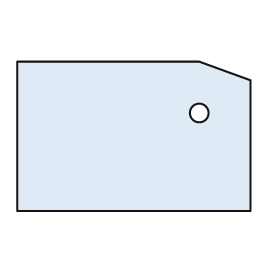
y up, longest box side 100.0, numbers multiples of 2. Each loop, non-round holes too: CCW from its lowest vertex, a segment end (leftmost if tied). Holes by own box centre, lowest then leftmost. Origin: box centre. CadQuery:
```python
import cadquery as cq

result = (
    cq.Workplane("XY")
    .moveTo(-50.0, -32.0)
    .lineTo(50.0, -32.0)
    .lineTo(50.0, 24.0)
    .lineTo(28.0, 32.0)
    .lineTo(-50.0, 32.0)
    .close()
    .moveTo(28.0, 10.0)
    .circle(4.0)
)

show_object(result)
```